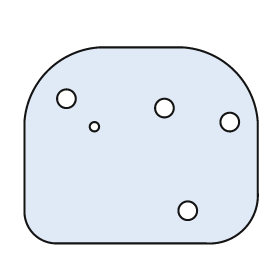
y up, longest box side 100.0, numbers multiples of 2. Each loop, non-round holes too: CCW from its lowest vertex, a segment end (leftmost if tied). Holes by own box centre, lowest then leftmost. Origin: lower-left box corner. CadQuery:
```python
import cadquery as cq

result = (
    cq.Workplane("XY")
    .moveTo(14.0, 0.0)
    .lineTo(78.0, 0.0)
    .threePointArc((94.0, 6.0), (100.0, 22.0))
    .lineTo(100.0, 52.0)
    .threePointArc((90.0, 74.0), (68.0, 84.0))
    .lineTo(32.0, 84.0)
    .threePointArc((10.0, 74.0), (0.0, 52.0))
    .lineTo(0.0, 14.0)
    .threePointArc((4.0, 4.0), (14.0, 0.0))
    .close()
    .moveTo(70.0, 14.0)
    .circle(4.0)
    .moveTo(30.0, 50.0)
    .circle(2.0)
    .moveTo(88.0, 52.0)
    .circle(4.0)
    .moveTo(60.0, 58.0)
    .circle(4.0)
    .moveTo(18.0, 62.0)
    .circle(4.0)
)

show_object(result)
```